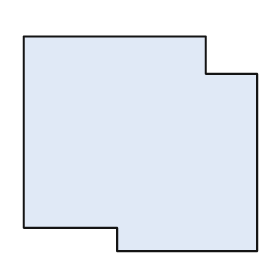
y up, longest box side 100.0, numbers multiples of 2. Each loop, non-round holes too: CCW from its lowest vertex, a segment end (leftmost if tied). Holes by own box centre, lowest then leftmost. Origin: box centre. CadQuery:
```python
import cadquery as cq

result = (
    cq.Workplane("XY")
    .moveTo(-10.0, -46.0)
    .lineTo(50.0, -46.0)
    .lineTo(50.0, 30.0)
    .lineTo(28.0, 30.0)
    .lineTo(28.0, 46.0)
    .lineTo(-50.0, 46.0)
    .lineTo(-50.0, -36.0)
    .lineTo(-10.0, -36.0)
    .close()
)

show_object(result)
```